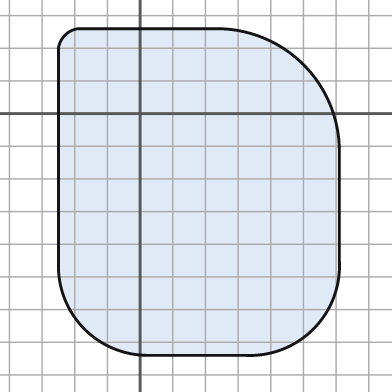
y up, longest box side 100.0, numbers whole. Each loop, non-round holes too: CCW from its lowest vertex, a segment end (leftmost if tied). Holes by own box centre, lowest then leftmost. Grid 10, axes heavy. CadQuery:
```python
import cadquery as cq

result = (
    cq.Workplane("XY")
    .moveTo(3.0, -74.0)
    .lineTo(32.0, -74.0)
    .threePointArc((53.0, -66.0), (61.0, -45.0))
    .lineTo(61.0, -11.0)
    .threePointArc((50.0, 15.0), (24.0, 26.0))
    .lineTo(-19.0, 26.0)
    .threePointArc((-23.0, 24.0), (-25.0, 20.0))
    .lineTo(-25.0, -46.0)
    .threePointArc((-17.0, -66.0), (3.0, -74.0))
    .close()
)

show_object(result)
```